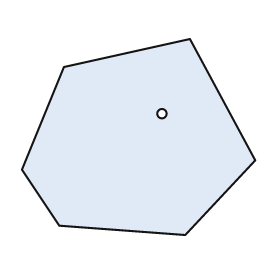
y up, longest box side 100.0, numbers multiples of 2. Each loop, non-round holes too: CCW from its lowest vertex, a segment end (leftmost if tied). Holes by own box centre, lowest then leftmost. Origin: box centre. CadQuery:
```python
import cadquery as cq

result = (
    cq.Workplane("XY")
    .moveTo(20.0, -42.0)
    .lineTo(50.0, -10.0)
    .lineTo(22.0, 42.0)
    .lineTo(-32.0, 30.0)
    .lineTo(-50.0, -14.0)
    .lineTo(-34.0, -38.0)
    .close()
    .moveTo(10.0, 10.0)
    .circle(2.0)
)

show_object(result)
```